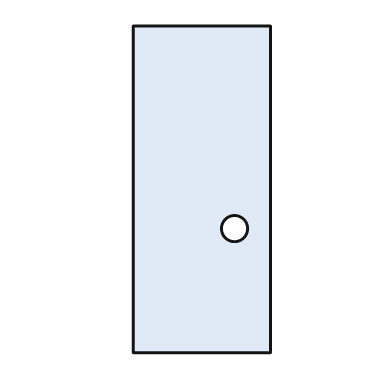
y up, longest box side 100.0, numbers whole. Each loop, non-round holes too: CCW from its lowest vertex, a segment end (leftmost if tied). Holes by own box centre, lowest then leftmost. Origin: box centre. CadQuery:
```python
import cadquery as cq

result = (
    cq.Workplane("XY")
    .moveTo(-21.0, -50.0)
    .lineTo(21.0, -50.0)
    .lineTo(21.0, 50.0)
    .lineTo(-21.0, 50.0)
    .close()
    .moveTo(10.0, -12.0)
    .circle(4.0)
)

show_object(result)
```